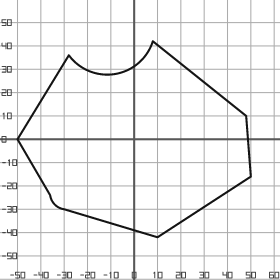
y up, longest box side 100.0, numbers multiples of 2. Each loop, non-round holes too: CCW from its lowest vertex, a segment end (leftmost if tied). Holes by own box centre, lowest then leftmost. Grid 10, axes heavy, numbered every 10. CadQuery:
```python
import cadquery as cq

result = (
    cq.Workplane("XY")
    .moveTo(10.0, -42.0)
    .lineTo(50.0, -16.0)
    .lineTo(48.0, 10.0)
    .lineTo(8.0, 42.0)
    .threePointArc((-8.0, 28.0), (-28.0, 36.0))
    .lineTo(-50.0, 0.0)
    .lineTo(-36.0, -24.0)
    .threePointArc((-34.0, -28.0), (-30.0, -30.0))
    .close()
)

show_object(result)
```